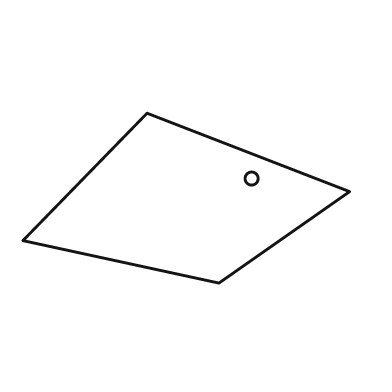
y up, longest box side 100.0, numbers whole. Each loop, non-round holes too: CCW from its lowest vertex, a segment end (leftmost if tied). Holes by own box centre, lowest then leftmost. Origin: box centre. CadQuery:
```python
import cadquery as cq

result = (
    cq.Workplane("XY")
    .moveTo(10.0, -26.0)
    .lineTo(50.0, 2.0)
    .lineTo(-12.0, 26.0)
    .lineTo(-50.0, -13.0)
    .close()
    .moveTo(20.0, 6.0)
    .circle(2.0)
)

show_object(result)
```